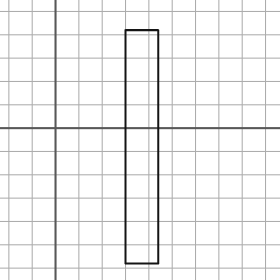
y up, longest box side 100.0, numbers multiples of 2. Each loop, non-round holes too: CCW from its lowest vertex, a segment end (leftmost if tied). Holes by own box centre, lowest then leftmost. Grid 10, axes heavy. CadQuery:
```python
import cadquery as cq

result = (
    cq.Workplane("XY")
    .moveTo(30.0, -58.0)
    .lineTo(44.0, -58.0)
    .lineTo(44.0, 42.0)
    .lineTo(30.0, 42.0)
    .close()
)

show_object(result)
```